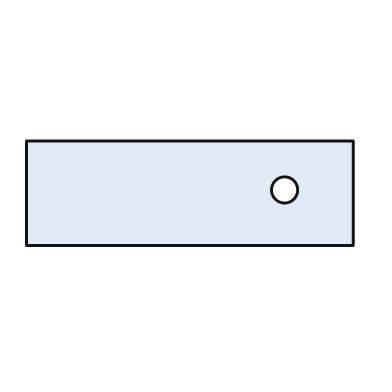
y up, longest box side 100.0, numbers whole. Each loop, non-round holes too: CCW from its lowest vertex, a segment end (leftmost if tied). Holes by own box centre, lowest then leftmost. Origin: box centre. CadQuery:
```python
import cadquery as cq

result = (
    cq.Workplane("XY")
    .moveTo(-50.0, -16.0)
    .lineTo(50.0, -16.0)
    .lineTo(50.0, 16.0)
    .lineTo(-50.0, 16.0)
    .close()
    .moveTo(29.0, 1.0)
    .circle(4.0)
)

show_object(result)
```